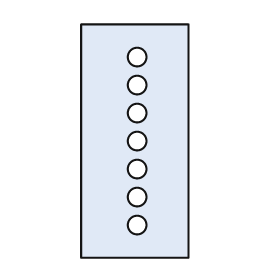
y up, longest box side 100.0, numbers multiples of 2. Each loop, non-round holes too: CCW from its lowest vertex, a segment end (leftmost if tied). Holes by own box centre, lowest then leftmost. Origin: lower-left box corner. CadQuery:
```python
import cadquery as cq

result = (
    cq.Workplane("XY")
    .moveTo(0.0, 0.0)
    .lineTo(46.0, 0.0)
    .lineTo(46.0, 100.0)
    .lineTo(0.0, 100.0)
    .close()
    .moveTo(24.0, 14.0)
    .circle(4.0)
    .moveTo(24.0, 26.0)
    .circle(4.0)
    .moveTo(24.0, 38.0)
    .circle(4.0)
    .moveTo(24.0, 50.0)
    .circle(4.0)
    .moveTo(24.0, 62.0)
    .circle(4.0)
    .moveTo(24.0, 74.0)
    .circle(4.0)
    .moveTo(24.0, 86.0)
    .circle(4.0)
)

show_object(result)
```